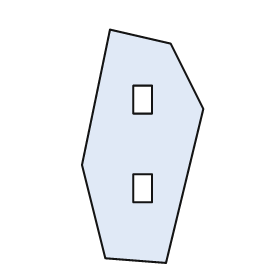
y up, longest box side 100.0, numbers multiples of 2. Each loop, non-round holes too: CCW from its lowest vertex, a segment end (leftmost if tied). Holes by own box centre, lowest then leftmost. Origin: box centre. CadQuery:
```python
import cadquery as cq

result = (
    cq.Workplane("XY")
    .moveTo(10.0, -50.0)
    .lineTo(26.0, 16.0)
    .lineTo(12.0, 44.0)
    .lineTo(-14.0, 50.0)
    .lineTo(-26.0, -8.0)
    .lineTo(-16.0, -48.0)
    .close()
    .moveTo(-4.0, -24.0)
    .lineTo(4.0, -24.0)
    .lineTo(4.0, -12.0)
    .lineTo(-4.0, -12.0)
    .close()
    .moveTo(-4.0, 14.0)
    .lineTo(4.0, 14.0)
    .lineTo(4.0, 26.0)
    .lineTo(-4.0, 26.0)
    .close()
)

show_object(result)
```